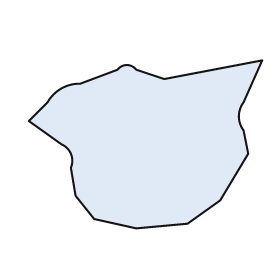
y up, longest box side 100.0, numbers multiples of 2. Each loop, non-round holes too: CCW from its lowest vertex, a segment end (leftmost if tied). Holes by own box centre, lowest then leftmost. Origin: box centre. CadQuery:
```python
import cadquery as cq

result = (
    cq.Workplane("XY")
    .moveTo(-4.0, -36.0)
    .lineTo(18.0, -34.0)
    .lineTo(32.0, -24.0)
    .lineTo(44.0, -4.0)
    .lineTo(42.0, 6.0)
    .threePointArc((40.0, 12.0), (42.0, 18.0))
    .lineTo(50.0, 36.0)
    .lineTo(8.0, 28.0)
    .lineTo(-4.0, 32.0)
    .threePointArc((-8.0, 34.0), (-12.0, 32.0))
    .lineTo(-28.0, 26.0)
    .threePointArc((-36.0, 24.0), (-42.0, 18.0))
    .lineTo(-50.0, 10.0)
    .lineTo(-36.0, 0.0)
    .threePointArc((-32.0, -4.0), (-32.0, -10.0))
    .lineTo(-30.0, -22.0)
    .lineTo(-22.0, -32.0)
    .close()
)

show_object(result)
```